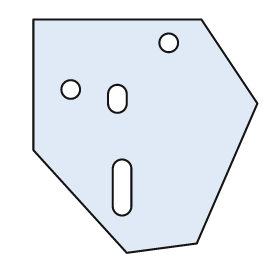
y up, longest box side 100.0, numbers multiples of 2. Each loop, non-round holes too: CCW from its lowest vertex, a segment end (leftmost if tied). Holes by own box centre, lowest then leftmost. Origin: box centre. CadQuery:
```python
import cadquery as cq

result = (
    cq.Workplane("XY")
    .moveTo(-8.0, -50.0)
    .lineTo(22.0, -46.0)
    .lineTo(48.0, 14.0)
    .lineTo(24.0, 50.0)
    .lineTo(-48.0, 50.0)
    .lineTo(-48.0, -6.0)
    .close()
    .moveTo(-14.0, -30.0)
    .threePointArc((-10.0, -34.0), (-6.0, -30.0))
    .lineTo(-6.0, -14.0)
    .threePointArc((-10.0, -10.0), (-14.0, -14.0))
    .close()
    .moveTo(-16.0, 14.0)
    .threePointArc((-12.0, 10.0), (-8.0, 14.0))
    .lineTo(-8.0, 18.0)
    .threePointArc((-12.0, 22.0), (-16.0, 18.0))
    .close()
    .moveTo(-32.0, 20.0)
    .circle(4.0)
    .moveTo(10.0, 40.0)
    .circle(4.0)
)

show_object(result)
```